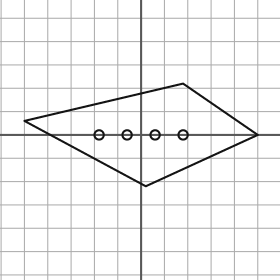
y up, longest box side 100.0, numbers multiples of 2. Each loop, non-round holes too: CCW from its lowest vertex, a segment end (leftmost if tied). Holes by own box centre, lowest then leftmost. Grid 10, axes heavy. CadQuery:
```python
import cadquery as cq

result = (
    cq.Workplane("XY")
    .moveTo(2.0, -22.0)
    .lineTo(50.0, 0.0)
    .lineTo(18.0, 22.0)
    .lineTo(-50.0, 6.0)
    .close()
    .moveTo(-18.0, 0.0)
    .circle(2.0)
    .moveTo(-6.0, 0.0)
    .circle(2.0)
    .moveTo(6.0, 0.0)
    .circle(2.0)
    .moveTo(18.0, 0.0)
    .circle(2.0)
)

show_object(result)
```